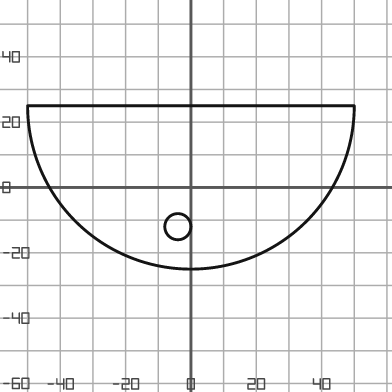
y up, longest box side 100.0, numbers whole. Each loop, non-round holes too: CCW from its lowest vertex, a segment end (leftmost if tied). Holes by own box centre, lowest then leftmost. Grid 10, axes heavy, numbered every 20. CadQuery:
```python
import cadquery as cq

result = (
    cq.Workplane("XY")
    .moveTo(-50.0, 25.0)
    .threePointArc((0.0, -25.0), (50.0, 25.0))
    .close()
    .moveTo(-4.0, -12.0)
    .circle(4.0)
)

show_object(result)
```